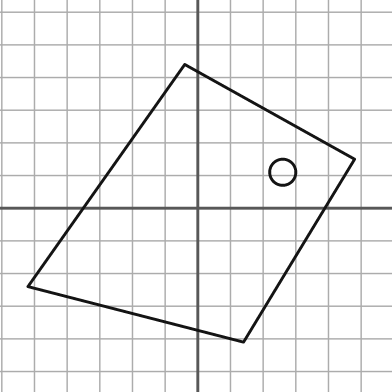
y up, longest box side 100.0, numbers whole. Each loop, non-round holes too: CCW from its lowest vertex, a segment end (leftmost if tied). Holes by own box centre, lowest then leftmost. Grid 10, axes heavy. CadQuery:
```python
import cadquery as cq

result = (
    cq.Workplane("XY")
    .moveTo(14.0, -41.0)
    .lineTo(48.0, 15.0)
    .lineTo(-4.0, 44.0)
    .lineTo(-52.0, -24.0)
    .close()
    .moveTo(26.0, 11.0)
    .circle(4.0)
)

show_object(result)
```